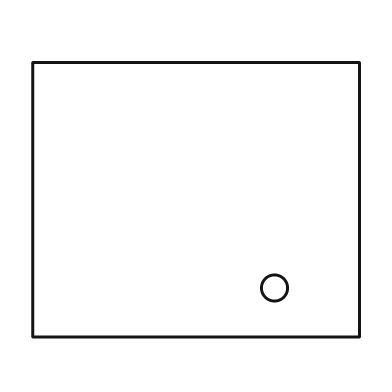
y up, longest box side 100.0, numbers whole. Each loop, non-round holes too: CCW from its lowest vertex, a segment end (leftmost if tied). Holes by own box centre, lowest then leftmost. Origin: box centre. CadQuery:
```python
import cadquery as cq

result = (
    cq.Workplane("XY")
    .moveTo(-50.0, -42.0)
    .lineTo(50.0, -42.0)
    .lineTo(50.0, 42.0)
    .lineTo(-50.0, 42.0)
    .close()
    .moveTo(24.0, -27.0)
    .circle(4.0)
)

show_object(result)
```